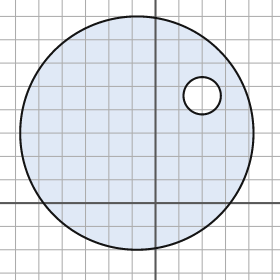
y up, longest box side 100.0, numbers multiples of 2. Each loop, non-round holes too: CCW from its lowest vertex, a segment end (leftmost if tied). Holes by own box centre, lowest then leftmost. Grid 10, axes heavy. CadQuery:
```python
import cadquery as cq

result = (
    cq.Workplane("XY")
    .moveTo(-8.0, 30.0)
    .circle(50.0)
    .moveTo(20.0, 46.0)
    .circle(8.0)
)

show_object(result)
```